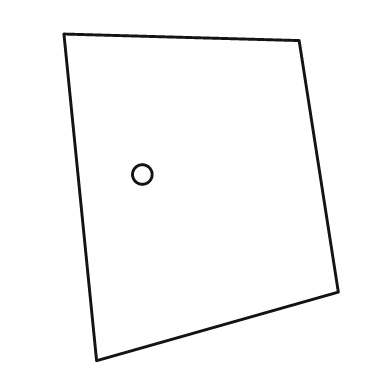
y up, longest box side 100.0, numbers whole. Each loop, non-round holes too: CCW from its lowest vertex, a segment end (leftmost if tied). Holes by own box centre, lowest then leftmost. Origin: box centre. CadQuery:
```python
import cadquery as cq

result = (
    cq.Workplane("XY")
    .moveTo(-32.0, -50.0)
    .lineTo(42.0, -29.0)
    .lineTo(30.0, 48.0)
    .lineTo(-42.0, 50.0)
    .close()
    .moveTo(-18.0, 7.0)
    .circle(3.0)
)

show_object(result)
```